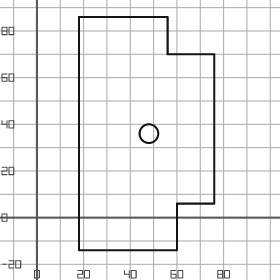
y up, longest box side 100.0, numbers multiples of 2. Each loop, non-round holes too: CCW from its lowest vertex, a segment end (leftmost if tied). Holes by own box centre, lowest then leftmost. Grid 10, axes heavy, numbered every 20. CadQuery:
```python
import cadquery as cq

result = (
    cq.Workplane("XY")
    .moveTo(18.0, -14.0)
    .lineTo(60.0, -14.0)
    .lineTo(60.0, 6.0)
    .lineTo(76.0, 6.0)
    .lineTo(76.0, 70.0)
    .lineTo(56.0, 70.0)
    .lineTo(56.0, 86.0)
    .lineTo(18.0, 86.0)
    .close()
    .moveTo(48.0, 36.0)
    .circle(4.0)
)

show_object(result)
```